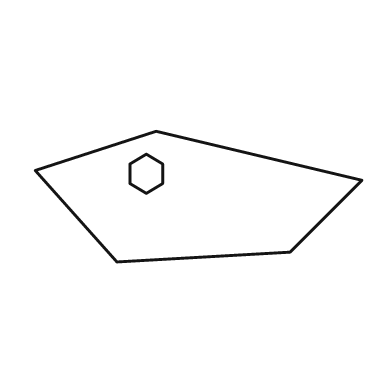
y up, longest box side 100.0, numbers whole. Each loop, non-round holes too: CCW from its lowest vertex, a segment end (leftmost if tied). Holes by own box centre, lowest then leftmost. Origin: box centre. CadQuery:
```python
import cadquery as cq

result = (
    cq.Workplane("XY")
    .moveTo(-25.0, -20.0)
    .lineTo(28.0, -17.0)
    .lineTo(50.0, 5.0)
    .lineTo(-13.0, 20.0)
    .lineTo(-50.0, 8.0)
    .close()
    .moveTo(-16.0, 1.0)
    .lineTo(-11.0, 4.0)
    .lineTo(-11.0, 10.0)
    .lineTo(-16.0, 13.0)
    .lineTo(-21.0, 10.0)
    .lineTo(-21.0, 4.0)
    .close()
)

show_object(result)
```